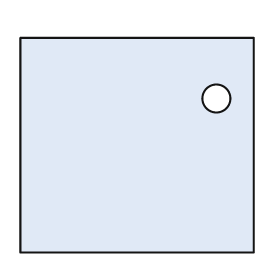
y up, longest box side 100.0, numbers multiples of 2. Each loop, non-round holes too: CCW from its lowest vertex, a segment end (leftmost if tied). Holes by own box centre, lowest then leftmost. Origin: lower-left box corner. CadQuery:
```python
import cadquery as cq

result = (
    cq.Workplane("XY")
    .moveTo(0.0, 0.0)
    .lineTo(100.0, 0.0)
    .lineTo(100.0, 92.0)
    .lineTo(0.0, 92.0)
    .close()
    .moveTo(84.0, 66.0)
    .circle(6.0)
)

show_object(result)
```